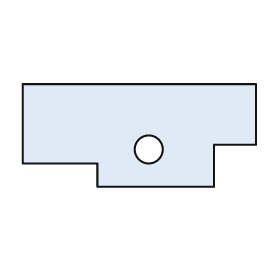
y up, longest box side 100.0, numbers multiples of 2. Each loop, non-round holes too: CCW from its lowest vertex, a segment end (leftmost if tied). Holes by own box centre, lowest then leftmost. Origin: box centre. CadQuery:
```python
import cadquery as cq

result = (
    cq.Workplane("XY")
    .moveTo(-18.0, -22.0)
    .lineTo(32.0, -22.0)
    .lineTo(32.0, -4.0)
    .lineTo(50.0, -4.0)
    .lineTo(50.0, 22.0)
    .lineTo(-50.0, 22.0)
    .lineTo(-50.0, -12.0)
    .lineTo(-18.0, -12.0)
    .close()
    .moveTo(4.0, -6.0)
    .circle(6.0)
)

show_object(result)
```